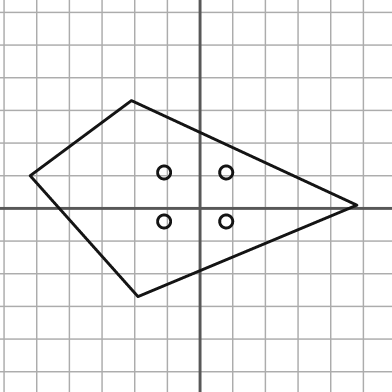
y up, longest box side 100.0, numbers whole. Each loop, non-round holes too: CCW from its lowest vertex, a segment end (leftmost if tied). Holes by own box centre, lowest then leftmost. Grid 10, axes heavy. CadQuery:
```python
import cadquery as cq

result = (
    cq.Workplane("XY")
    .moveTo(-19.0, -27.0)
    .lineTo(48.0, 1.0)
    .lineTo(-21.0, 33.0)
    .lineTo(-52.0, 10.0)
    .close()
    .moveTo(-11.0, -4.0)
    .circle(2.0)
    .moveTo(8.0, -4.0)
    .circle(2.0)
    .moveTo(-11.0, 11.0)
    .circle(2.0)
    .moveTo(8.0, 11.0)
    .circle(2.0)
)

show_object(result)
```